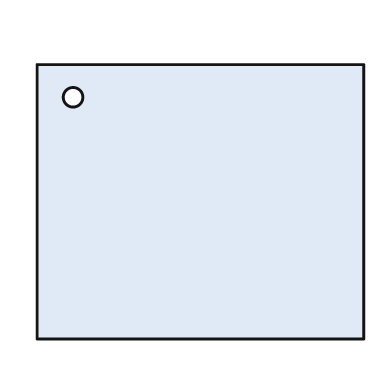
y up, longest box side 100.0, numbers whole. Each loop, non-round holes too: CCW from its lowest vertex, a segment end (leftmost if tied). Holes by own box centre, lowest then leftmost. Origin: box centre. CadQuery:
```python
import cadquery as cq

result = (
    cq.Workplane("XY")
    .moveTo(-50.0, -42.0)
    .lineTo(50.0, -42.0)
    .lineTo(50.0, 42.0)
    .lineTo(-50.0, 42.0)
    .close()
    .moveTo(-39.0, 32.0)
    .circle(3.0)
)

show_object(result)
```